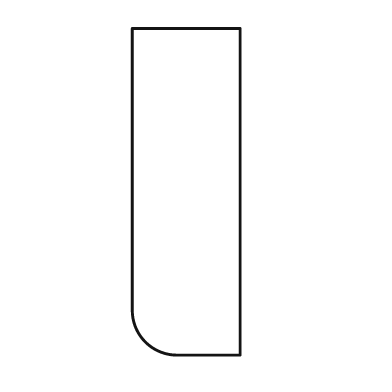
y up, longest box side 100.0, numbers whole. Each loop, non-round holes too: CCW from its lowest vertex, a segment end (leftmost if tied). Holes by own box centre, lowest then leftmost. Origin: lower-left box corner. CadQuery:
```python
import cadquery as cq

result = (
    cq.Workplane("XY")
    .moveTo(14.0, 0.0)
    .lineTo(33.0, 0.0)
    .lineTo(33.0, 100.0)
    .lineTo(0.0, 100.0)
    .lineTo(0.0, 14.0)
    .threePointArc((4.0, 4.0), (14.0, 0.0))
    .close()
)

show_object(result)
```